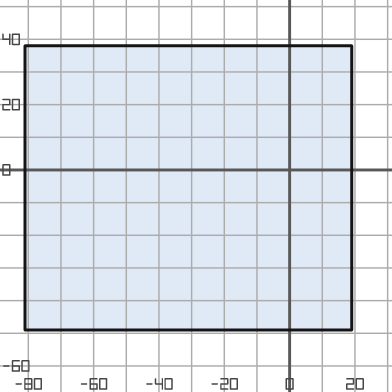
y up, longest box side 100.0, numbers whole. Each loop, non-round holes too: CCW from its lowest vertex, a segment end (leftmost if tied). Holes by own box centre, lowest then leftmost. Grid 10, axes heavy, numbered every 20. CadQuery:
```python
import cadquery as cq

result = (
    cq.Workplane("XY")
    .moveTo(-81.0, -49.0)
    .lineTo(19.0, -49.0)
    .lineTo(19.0, 38.0)
    .lineTo(-81.0, 38.0)
    .close()
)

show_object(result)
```